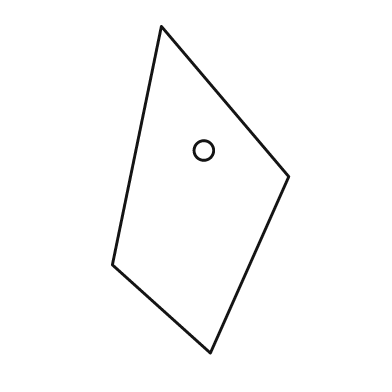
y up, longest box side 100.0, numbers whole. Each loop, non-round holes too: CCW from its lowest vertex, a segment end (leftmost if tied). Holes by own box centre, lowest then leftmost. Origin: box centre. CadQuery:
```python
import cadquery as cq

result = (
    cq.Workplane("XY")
    .moveTo(3.0, -50.0)
    .lineTo(27.0, 4.0)
    .lineTo(-12.0, 50.0)
    .lineTo(-27.0, -23.0)
    .close()
    .moveTo(1.0, 12.0)
    .circle(3.0)
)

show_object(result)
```